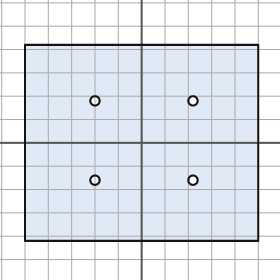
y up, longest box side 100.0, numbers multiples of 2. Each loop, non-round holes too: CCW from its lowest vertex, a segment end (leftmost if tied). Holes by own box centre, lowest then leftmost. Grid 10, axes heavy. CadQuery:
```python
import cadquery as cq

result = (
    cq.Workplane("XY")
    .moveTo(-50.0, -42.0)
    .lineTo(50.0, -42.0)
    .lineTo(50.0, 42.0)
    .lineTo(-50.0, 42.0)
    .close()
    .moveTo(-20.0, -16.0)
    .circle(2.0)
    .moveTo(22.0, -16.0)
    .circle(2.0)
    .moveTo(-20.0, 18.0)
    .circle(2.0)
    .moveTo(22.0, 18.0)
    .circle(2.0)
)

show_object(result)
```